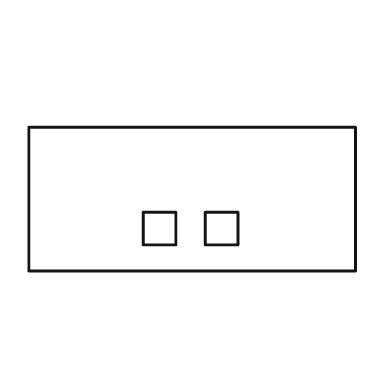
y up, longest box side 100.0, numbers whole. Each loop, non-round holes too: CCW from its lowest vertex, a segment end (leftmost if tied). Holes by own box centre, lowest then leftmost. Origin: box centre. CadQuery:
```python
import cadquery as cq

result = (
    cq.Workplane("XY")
    .moveTo(-50.0, -22.0)
    .lineTo(50.0, -22.0)
    .lineTo(50.0, 22.0)
    .lineTo(-50.0, 22.0)
    .close()
    .moveTo(-15.0, -14.0)
    .lineTo(-5.0, -14.0)
    .lineTo(-5.0, -4.0)
    .lineTo(-15.0, -4.0)
    .close()
    .moveTo(4.0, -14.0)
    .lineTo(14.0, -14.0)
    .lineTo(14.0, -4.0)
    .lineTo(4.0, -4.0)
    .close()
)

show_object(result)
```